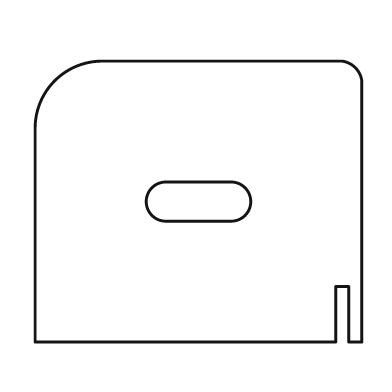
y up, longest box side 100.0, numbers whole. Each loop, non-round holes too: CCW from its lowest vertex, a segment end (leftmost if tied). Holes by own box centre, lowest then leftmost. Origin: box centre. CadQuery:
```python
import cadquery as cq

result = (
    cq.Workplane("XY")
    .moveTo(-50.0, -43.0)
    .lineTo(42.0, -43.0)
    .lineTo(42.0, -26.0)
    .lineTo(46.0, -26.0)
    .lineTo(46.0, -43.0)
    .lineTo(50.0, -43.0)
    .lineTo(50.0, 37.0)
    .threePointArc((48.0, 41.0), (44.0, 43.0))
    .lineTo(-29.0, 43.0)
    .threePointArc((-44.0, 37.0), (-50.0, 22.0))
    .close()
    .moveTo(-10.0, -6.0)
    .lineTo(10.0, -6.0)
    .threePointArc((16.0, 0.0), (10.0, 6.0))
    .lineTo(-10.0, 6.0)
    .threePointArc((-16.0, 0.0), (-10.0, -6.0))
    .close()
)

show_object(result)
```